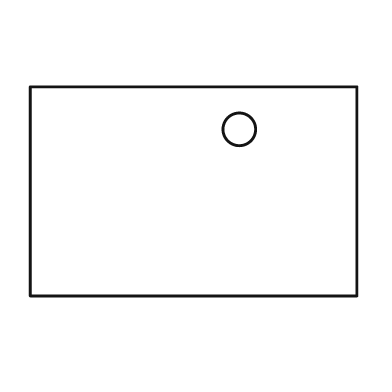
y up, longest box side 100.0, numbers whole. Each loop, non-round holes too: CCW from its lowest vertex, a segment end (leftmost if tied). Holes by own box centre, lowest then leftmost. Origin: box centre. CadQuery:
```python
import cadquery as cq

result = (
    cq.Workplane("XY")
    .moveTo(-50.0, -32.0)
    .lineTo(50.0, -32.0)
    .lineTo(50.0, 32.0)
    .lineTo(-50.0, 32.0)
    .close()
    .moveTo(14.0, 19.0)
    .circle(5.0)
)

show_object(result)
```